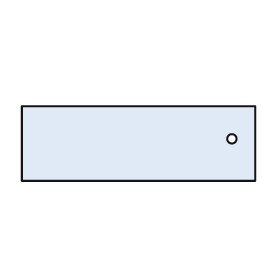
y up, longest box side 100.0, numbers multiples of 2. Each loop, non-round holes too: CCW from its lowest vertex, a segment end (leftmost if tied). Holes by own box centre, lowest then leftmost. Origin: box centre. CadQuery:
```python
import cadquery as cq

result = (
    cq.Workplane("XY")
    .moveTo(-50.0, -16.0)
    .lineTo(50.0, -16.0)
    .lineTo(50.0, 16.0)
    .lineTo(-50.0, 16.0)
    .close()
    .moveTo(40.0, 2.0)
    .circle(2.0)
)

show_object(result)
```